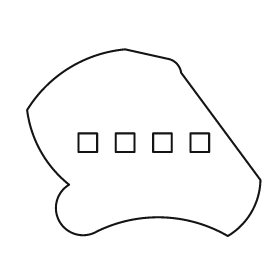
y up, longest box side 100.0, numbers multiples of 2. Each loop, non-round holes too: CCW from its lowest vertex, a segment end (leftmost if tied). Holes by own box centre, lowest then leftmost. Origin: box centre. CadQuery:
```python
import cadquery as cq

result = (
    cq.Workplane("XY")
    .moveTo(36.0, -40.0)
    .threePointArc((46.0, -30.0), (50.0, -16.0))
    .lineTo(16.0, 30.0)
    .threePointArc((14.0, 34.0), (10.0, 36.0))
    .lineTo(-8.0, 40.0)
    .threePointArc((-32.0, 32.0), (-50.0, 14.0))
    .threePointArc((-44.0, -4.0), (-32.0, -18.0))
    .threePointArc((-36.0, -34.0), (-20.0, -38.0))
    .threePointArc((8.0, -32.0), (36.0, -40.0))
    .close()
    .moveTo(-28.0, -4.0)
    .lineTo(-20.0, -4.0)
    .lineTo(-20.0, 4.0)
    .lineTo(-28.0, 4.0)
    .close()
    .moveTo(-12.0, -4.0)
    .lineTo(-4.0, -4.0)
    .lineTo(-4.0, 4.0)
    .lineTo(-12.0, 4.0)
    .close()
    .moveTo(4.0, -4.0)
    .lineTo(12.0, -4.0)
    .lineTo(12.0, 4.0)
    .lineTo(4.0, 4.0)
    .close()
    .moveTo(20.0, -4.0)
    .lineTo(28.0, -4.0)
    .lineTo(28.0, 4.0)
    .lineTo(20.0, 4.0)
    .close()
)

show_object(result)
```